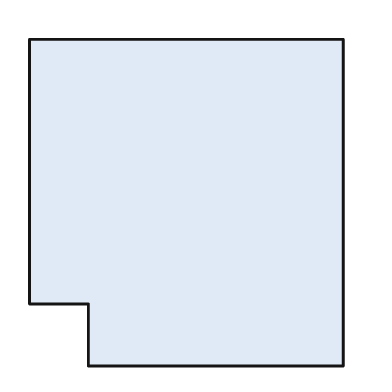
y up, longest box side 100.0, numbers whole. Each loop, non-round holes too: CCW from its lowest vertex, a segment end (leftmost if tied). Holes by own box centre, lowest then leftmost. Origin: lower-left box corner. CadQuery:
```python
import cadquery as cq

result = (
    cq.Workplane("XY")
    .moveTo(18.0, 0.0)
    .lineTo(96.0, 0.0)
    .lineTo(96.0, 100.0)
    .lineTo(0.0, 100.0)
    .lineTo(0.0, 19.0)
    .lineTo(18.0, 19.0)
    .close()
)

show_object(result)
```